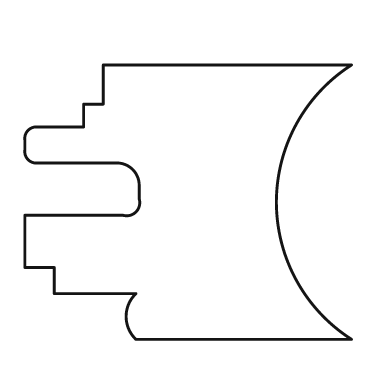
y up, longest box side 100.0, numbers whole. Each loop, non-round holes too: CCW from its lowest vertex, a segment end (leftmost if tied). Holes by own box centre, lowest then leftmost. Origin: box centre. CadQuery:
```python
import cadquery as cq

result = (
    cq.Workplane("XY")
    .moveTo(-16.0, -42.0)
    .lineTo(50.0, -42.0)
    .threePointArc((27.0, 0.0), (50.0, 42.0))
    .lineTo(-26.0, 42.0)
    .lineTo(-26.0, 30.0)
    .lineTo(-32.0, 30.0)
    .lineTo(-32.0, 23.0)
    .lineTo(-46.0, 23.0)
    .threePointArc((-49.0, 22.0), (-50.0, 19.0))
    .lineTo(-50.0, 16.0)
    .threePointArc((-49.0, 13.0), (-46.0, 12.0))
    .lineTo(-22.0, 12.0)
    .threePointArc((-17.0, 10.0), (-15.0, 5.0))
    .lineTo(-15.0, 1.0)
    .threePointArc((-16.0, -3.0), (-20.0, -4.0))
    .lineTo(-50.0, -4.0)
    .lineTo(-50.0, -20.0)
    .lineTo(-41.0, -20.0)
    .lineTo(-41.0, -28.0)
    .lineTo(-16.0, -28.0)
    .threePointArc((-19.0, -35.0), (-16.0, -42.0))
    .close()
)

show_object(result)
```